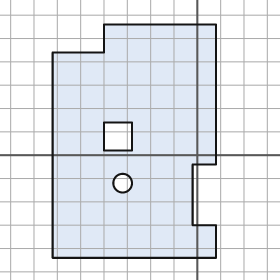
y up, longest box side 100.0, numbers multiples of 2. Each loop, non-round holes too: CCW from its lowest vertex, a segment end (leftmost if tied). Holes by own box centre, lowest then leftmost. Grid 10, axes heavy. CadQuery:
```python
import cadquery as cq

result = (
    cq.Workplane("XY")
    .moveTo(-62.0, -44.0)
    .lineTo(8.0, -44.0)
    .lineTo(8.0, -30.0)
    .lineTo(-2.0, -30.0)
    .lineTo(-2.0, -4.0)
    .lineTo(8.0, -4.0)
    .lineTo(8.0, 56.0)
    .lineTo(-40.0, 56.0)
    .lineTo(-40.0, 44.0)
    .lineTo(-62.0, 44.0)
    .close()
    .moveTo(-32.0, -12.0)
    .circle(4.0)
    .moveTo(-40.0, 2.0)
    .lineTo(-28.0, 2.0)
    .lineTo(-28.0, 14.0)
    .lineTo(-40.0, 14.0)
    .close()
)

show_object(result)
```